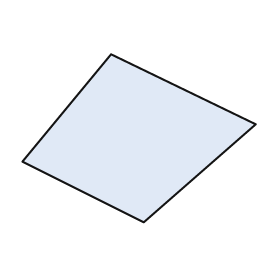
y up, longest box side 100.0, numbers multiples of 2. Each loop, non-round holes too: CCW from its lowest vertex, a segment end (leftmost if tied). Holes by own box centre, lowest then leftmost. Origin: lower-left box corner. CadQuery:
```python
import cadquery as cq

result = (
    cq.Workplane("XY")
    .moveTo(52.0, 0.0)
    .lineTo(100.0, 42.0)
    .lineTo(38.0, 72.0)
    .lineTo(0.0, 26.0)
    .close()
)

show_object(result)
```